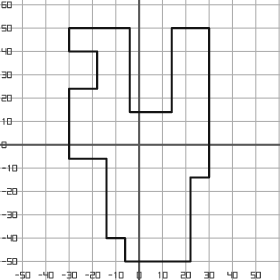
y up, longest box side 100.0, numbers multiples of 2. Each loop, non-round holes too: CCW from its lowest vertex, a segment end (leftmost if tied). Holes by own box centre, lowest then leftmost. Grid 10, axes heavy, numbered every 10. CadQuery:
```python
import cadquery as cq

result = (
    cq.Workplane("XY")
    .moveTo(-6.0, -50.0)
    .lineTo(22.0, -50.0)
    .lineTo(22.0, -14.0)
    .lineTo(30.0, -14.0)
    .lineTo(30.0, 50.0)
    .lineTo(14.0, 50.0)
    .lineTo(14.0, 14.0)
    .lineTo(-4.0, 14.0)
    .lineTo(-4.0, 50.0)
    .lineTo(-30.0, 50.0)
    .lineTo(-30.0, 40.0)
    .lineTo(-18.0, 40.0)
    .lineTo(-18.0, 24.0)
    .lineTo(-30.0, 24.0)
    .lineTo(-30.0, -6.0)
    .lineTo(-14.0, -6.0)
    .lineTo(-14.0, -40.0)
    .lineTo(-6.0, -40.0)
    .close()
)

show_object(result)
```